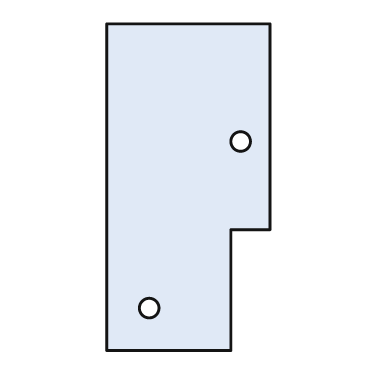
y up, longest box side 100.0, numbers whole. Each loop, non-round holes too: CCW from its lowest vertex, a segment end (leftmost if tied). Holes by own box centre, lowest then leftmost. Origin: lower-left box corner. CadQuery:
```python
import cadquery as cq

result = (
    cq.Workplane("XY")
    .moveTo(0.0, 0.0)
    .lineTo(38.0, 0.0)
    .lineTo(38.0, 37.0)
    .lineTo(50.0, 37.0)
    .lineTo(50.0, 100.0)
    .lineTo(0.0, 100.0)
    .close()
    .moveTo(13.0, 13.0)
    .circle(3.0)
    .moveTo(41.0, 64.0)
    .circle(3.0)
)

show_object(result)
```